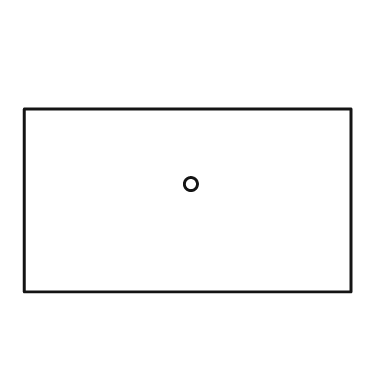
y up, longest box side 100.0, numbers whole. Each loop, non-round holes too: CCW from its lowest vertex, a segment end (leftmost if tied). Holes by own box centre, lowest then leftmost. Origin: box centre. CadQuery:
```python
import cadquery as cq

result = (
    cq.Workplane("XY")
    .moveTo(-50.0, -28.0)
    .lineTo(50.0, -28.0)
    .lineTo(50.0, 28.0)
    .lineTo(-50.0, 28.0)
    .close()
    .moveTo(1.0, 5.0)
    .circle(2.0)
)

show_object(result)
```